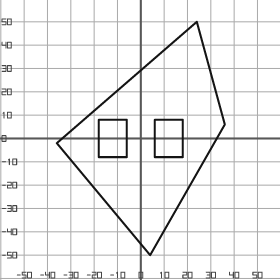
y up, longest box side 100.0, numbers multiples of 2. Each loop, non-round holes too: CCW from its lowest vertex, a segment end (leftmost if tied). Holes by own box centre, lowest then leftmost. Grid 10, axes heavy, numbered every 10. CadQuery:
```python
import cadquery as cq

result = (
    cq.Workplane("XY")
    .moveTo(4.0, -50.0)
    .lineTo(36.0, 6.0)
    .lineTo(24.0, 50.0)
    .lineTo(-36.0, -2.0)
    .close()
    .moveTo(-18.0, -8.0)
    .lineTo(-6.0, -8.0)
    .lineTo(-6.0, 8.0)
    .lineTo(-18.0, 8.0)
    .close()
    .moveTo(6.0, -8.0)
    .lineTo(18.0, -8.0)
    .lineTo(18.0, 8.0)
    .lineTo(6.0, 8.0)
    .close()
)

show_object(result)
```